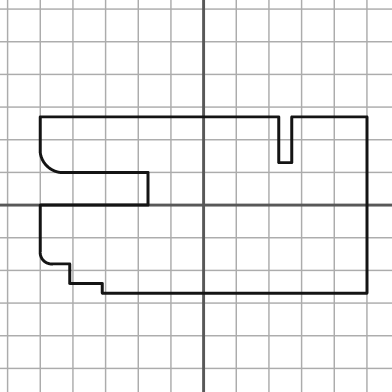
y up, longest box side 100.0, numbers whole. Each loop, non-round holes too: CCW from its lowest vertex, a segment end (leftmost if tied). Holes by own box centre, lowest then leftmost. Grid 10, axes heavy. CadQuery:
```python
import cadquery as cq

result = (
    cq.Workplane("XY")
    .moveTo(-31.0, -27.0)
    .lineTo(50.0, -27.0)
    .lineTo(50.0, 27.0)
    .lineTo(27.0, 27.0)
    .lineTo(27.0, 13.0)
    .lineTo(23.0, 13.0)
    .lineTo(23.0, 27.0)
    .lineTo(-50.0, 27.0)
    .lineTo(-50.0, 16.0)
    .threePointArc((-48.0, 12.0), (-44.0, 10.0))
    .lineTo(-17.0, 10.0)
    .lineTo(-17.0, 0.0)
    .lineTo(-50.0, 0.0)
    .lineTo(-50.0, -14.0)
    .threePointArc((-49.0, -17.0), (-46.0, -18.0))
    .lineTo(-41.0, -18.0)
    .lineTo(-41.0, -24.0)
    .lineTo(-31.0, -24.0)
    .close()
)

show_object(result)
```